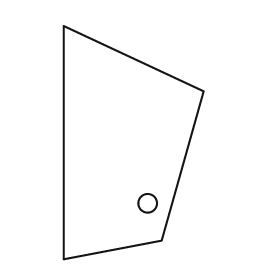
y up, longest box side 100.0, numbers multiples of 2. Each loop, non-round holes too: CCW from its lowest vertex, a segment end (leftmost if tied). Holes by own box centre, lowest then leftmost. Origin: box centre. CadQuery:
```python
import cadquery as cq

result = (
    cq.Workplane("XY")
    .moveTo(-30.0, -50.0)
    .lineTo(12.0, -42.0)
    .lineTo(30.0, 22.0)
    .lineTo(-30.0, 50.0)
    .close()
    .moveTo(6.0, -26.0)
    .circle(4.0)
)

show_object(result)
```